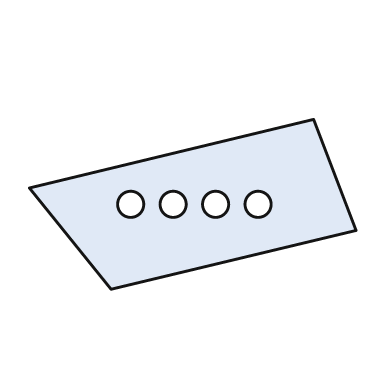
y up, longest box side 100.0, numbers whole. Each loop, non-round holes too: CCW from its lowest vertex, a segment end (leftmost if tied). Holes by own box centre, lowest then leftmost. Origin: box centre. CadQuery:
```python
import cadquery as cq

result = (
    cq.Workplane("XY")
    .moveTo(-25.0, -26.0)
    .lineTo(50.0, -8.0)
    .lineTo(37.0, 26.0)
    .lineTo(-50.0, 5.0)
    .close()
    .moveTo(-19.0, 0.0)
    .circle(4.0)
    .moveTo(-6.0, 0.0)
    .circle(4.0)
    .moveTo(7.0, 0.0)
    .circle(4.0)
    .moveTo(20.0, 0.0)
    .circle(4.0)
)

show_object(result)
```